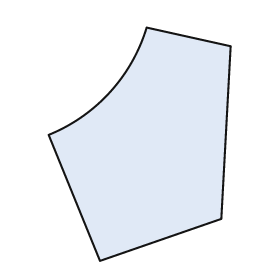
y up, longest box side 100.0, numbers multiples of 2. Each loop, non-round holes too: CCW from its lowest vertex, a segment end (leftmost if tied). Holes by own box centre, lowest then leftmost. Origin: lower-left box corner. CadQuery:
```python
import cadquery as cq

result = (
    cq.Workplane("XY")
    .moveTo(22.0, 0.0)
    .lineTo(74.0, 18.0)
    .lineTo(78.0, 92.0)
    .lineTo(42.0, 100.0)
    .threePointArc((26.0, 72.0), (0.0, 54.0))
    .close()
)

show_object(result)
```